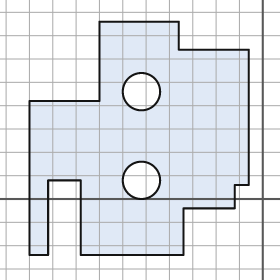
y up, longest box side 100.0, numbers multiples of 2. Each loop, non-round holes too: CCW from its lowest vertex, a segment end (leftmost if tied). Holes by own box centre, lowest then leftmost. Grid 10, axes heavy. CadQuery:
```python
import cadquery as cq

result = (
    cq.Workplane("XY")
    .moveTo(-100.0, -24.0)
    .lineTo(-92.0, -24.0)
    .lineTo(-92.0, 8.0)
    .lineTo(-78.0, 8.0)
    .lineTo(-78.0, -24.0)
    .lineTo(-34.0, -24.0)
    .lineTo(-34.0, -4.0)
    .lineTo(-12.0, -4.0)
    .lineTo(-12.0, 6.0)
    .lineTo(-6.0, 6.0)
    .lineTo(-6.0, 64.0)
    .lineTo(-36.0, 64.0)
    .lineTo(-36.0, 76.0)
    .lineTo(-70.0, 76.0)
    .lineTo(-70.0, 42.0)
    .lineTo(-100.0, 42.0)
    .close()
    .moveTo(-52.0, 8.0)
    .circle(8.0)
    .moveTo(-52.0, 46.0)
    .circle(8.0)
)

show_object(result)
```